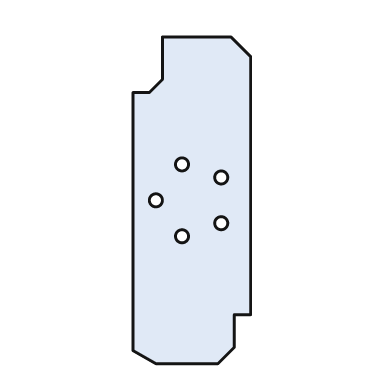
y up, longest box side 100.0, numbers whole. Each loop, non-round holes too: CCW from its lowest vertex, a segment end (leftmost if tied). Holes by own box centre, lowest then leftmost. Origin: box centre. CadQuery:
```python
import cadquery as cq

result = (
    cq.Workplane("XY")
    .moveTo(-11.0, -50.0)
    .lineTo(8.0, -50.0)
    .lineTo(13.0, -45.0)
    .lineTo(13.0, -35.0)
    .lineTo(18.0, -35.0)
    .lineTo(18.0, 44.0)
    .lineTo(12.0, 50.0)
    .lineTo(-9.0, 50.0)
    .lineTo(-9.0, 37.0)
    .lineTo(-13.0, 33.0)
    .lineTo(-18.0, 33.0)
    .lineTo(-18.0, -46.0)
    .close()
    .moveTo(-3.0, -11.0)
    .circle(2.0)
    .moveTo(9.0, -7.0)
    .circle(2.0)
    .moveTo(-11.0, 0.0)
    .circle(2.0)
    .moveTo(9.0, 7.0)
    .circle(2.0)
    .moveTo(-3.0, 11.0)
    .circle(2.0)
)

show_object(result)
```